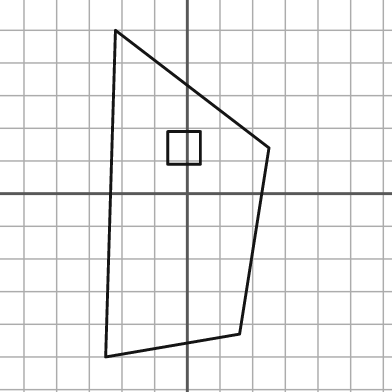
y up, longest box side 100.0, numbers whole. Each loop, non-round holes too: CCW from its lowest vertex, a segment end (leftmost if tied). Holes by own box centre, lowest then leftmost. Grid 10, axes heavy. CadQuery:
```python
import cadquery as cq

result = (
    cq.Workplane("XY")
    .moveTo(-25.0, -50.0)
    .lineTo(16.0, -43.0)
    .lineTo(25.0, 14.0)
    .lineTo(-22.0, 50.0)
    .close()
    .moveTo(-6.0, 9.0)
    .lineTo(4.0, 9.0)
    .lineTo(4.0, 19.0)
    .lineTo(-6.0, 19.0)
    .close()
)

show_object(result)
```